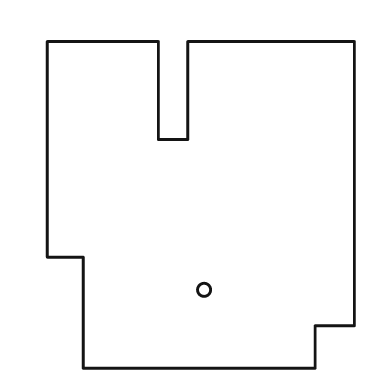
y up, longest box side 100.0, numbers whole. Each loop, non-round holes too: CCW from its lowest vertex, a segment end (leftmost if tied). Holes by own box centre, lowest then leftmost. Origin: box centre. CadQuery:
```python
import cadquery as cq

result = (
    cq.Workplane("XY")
    .moveTo(-36.0, -50.0)
    .lineTo(35.0, -50.0)
    .lineTo(35.0, -37.0)
    .lineTo(47.0, -37.0)
    .lineTo(47.0, 50.0)
    .lineTo(-4.0, 50.0)
    .lineTo(-4.0, 20.0)
    .lineTo(-13.0, 20.0)
    .lineTo(-13.0, 50.0)
    .lineTo(-47.0, 50.0)
    .lineTo(-47.0, -16.0)
    .lineTo(-36.0, -16.0)
    .close()
    .moveTo(1.0, -26.0)
    .circle(2.0)
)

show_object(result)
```